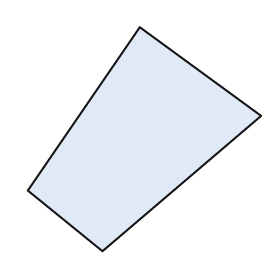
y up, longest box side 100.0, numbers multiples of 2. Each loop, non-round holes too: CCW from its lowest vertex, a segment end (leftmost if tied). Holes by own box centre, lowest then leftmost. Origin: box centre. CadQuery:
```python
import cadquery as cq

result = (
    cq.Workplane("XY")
    .moveTo(-18.0, -48.0)
    .lineTo(50.0, 10.0)
    .lineTo(-2.0, 48.0)
    .lineTo(-50.0, -22.0)
    .close()
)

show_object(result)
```